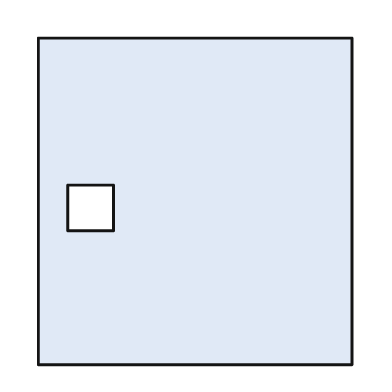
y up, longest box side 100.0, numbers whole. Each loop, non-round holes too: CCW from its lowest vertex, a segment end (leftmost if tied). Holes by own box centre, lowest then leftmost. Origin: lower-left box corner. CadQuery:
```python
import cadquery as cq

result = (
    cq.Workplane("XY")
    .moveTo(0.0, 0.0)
    .lineTo(96.0, 0.0)
    .lineTo(96.0, 100.0)
    .lineTo(0.0, 100.0)
    .close()
    .moveTo(9.0, 41.0)
    .lineTo(23.0, 41.0)
    .lineTo(23.0, 55.0)
    .lineTo(9.0, 55.0)
    .close()
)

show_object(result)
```